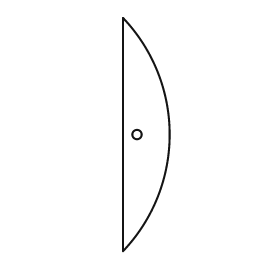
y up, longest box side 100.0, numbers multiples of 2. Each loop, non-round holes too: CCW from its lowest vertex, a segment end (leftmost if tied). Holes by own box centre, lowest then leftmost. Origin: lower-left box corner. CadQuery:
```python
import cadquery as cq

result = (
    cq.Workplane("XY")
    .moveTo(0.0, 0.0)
    .threePointArc((20.0, 50.0), (0.0, 100.0))
    .close()
    .moveTo(6.0, 50.0)
    .circle(2.0)
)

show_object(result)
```